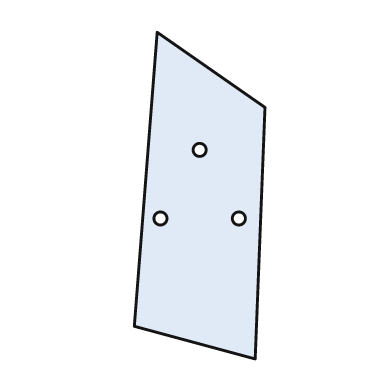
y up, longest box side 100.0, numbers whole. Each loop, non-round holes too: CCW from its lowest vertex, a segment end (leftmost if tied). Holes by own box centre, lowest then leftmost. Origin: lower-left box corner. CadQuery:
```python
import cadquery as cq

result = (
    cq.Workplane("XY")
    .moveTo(37.0, 0.0)
    .lineTo(40.0, 77.0)
    .lineTo(7.0, 100.0)
    .lineTo(0.0, 10.0)
    .close()
    .moveTo(8.0, 43.0)
    .circle(2.0)
    .moveTo(32.0, 43.0)
    .circle(2.0)
    .moveTo(20.0, 64.0)
    .circle(2.0)
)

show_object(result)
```